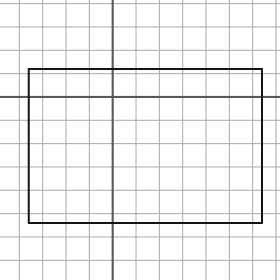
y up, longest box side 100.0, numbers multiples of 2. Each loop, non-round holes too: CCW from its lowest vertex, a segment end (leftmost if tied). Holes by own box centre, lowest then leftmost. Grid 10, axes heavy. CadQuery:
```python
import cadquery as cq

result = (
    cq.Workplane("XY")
    .moveTo(-36.0, -54.0)
    .lineTo(64.0, -54.0)
    .lineTo(64.0, 12.0)
    .lineTo(-36.0, 12.0)
    .close()
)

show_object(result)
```